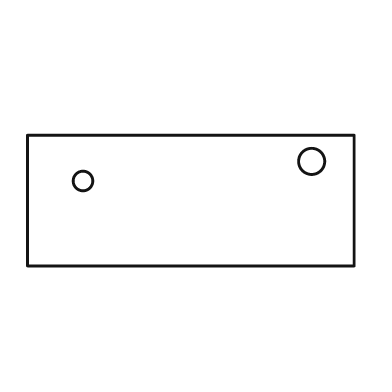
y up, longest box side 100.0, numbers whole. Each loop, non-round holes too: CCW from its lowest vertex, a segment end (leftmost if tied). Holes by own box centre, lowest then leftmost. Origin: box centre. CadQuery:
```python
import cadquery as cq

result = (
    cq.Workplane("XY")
    .moveTo(-50.0, -20.0)
    .lineTo(50.0, -20.0)
    .lineTo(50.0, 20.0)
    .lineTo(-50.0, 20.0)
    .close()
    .moveTo(-33.0, 6.0)
    .circle(3.0)
    .moveTo(37.0, 12.0)
    .circle(4.0)
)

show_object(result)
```